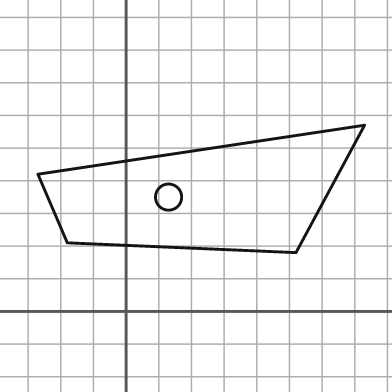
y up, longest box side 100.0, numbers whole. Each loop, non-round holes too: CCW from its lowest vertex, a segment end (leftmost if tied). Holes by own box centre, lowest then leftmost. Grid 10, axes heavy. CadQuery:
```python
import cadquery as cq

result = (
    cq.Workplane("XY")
    .moveTo(52.0, 18.0)
    .lineTo(73.0, 57.0)
    .lineTo(-27.0, 42.0)
    .lineTo(-18.0, 21.0)
    .close()
    .moveTo(13.0, 35.0)
    .circle(4.0)
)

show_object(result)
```